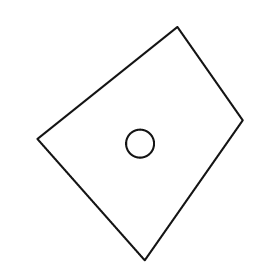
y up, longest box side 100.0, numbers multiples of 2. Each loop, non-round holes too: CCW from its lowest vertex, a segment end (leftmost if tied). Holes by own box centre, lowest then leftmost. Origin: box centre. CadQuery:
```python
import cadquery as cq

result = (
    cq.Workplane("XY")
    .moveTo(2.0, -50.0)
    .lineTo(44.0, 10.0)
    .lineTo(16.0, 50.0)
    .lineTo(-44.0, 2.0)
    .close()
    .moveTo(0.0, 0.0)
    .circle(6.0)
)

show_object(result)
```